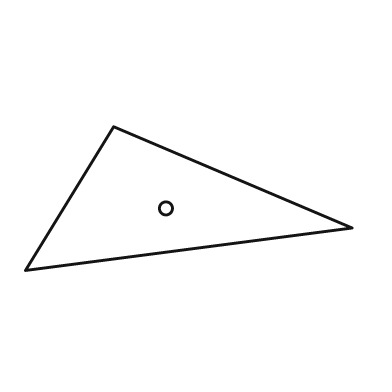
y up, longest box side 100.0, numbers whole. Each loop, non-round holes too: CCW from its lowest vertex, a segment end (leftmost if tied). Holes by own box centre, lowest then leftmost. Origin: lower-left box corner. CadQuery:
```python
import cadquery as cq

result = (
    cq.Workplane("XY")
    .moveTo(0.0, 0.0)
    .lineTo(100.0, 13.0)
    .lineTo(27.0, 44.0)
    .close()
    .moveTo(43.0, 19.0)
    .circle(2.0)
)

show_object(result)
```